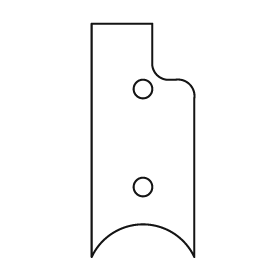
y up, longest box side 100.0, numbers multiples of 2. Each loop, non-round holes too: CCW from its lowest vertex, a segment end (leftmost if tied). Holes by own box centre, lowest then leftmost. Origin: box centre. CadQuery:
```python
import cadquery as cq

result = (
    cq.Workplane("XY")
    .moveTo(-22.0, -50.0)
    .threePointArc((0.0, -36.0), (22.0, -50.0))
    .lineTo(22.0, 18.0)
    .threePointArc((20.0, 24.0), (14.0, 26.0))
    .lineTo(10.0, 26.0)
    .threePointArc((6.0, 28.0), (4.0, 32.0))
    .lineTo(4.0, 50.0)
    .lineTo(-22.0, 50.0)
    .close()
    .moveTo(0.0, -20.0)
    .circle(4.0)
    .moveTo(0.0, 22.0)
    .circle(4.0)
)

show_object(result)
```